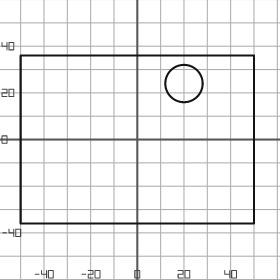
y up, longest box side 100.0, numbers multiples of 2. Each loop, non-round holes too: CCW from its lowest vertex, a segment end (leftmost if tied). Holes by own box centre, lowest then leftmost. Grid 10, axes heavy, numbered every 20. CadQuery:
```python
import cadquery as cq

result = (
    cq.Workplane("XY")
    .moveTo(-50.0, -36.0)
    .lineTo(50.0, -36.0)
    .lineTo(50.0, 36.0)
    .lineTo(-50.0, 36.0)
    .close()
    .moveTo(20.0, 24.0)
    .circle(8.0)
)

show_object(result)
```